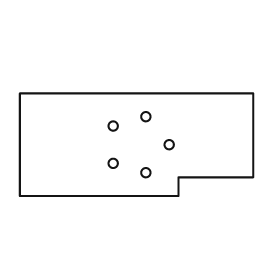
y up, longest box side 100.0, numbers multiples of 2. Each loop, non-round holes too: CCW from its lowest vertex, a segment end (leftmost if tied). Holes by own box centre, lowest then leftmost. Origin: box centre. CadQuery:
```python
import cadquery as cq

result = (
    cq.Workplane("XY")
    .moveTo(-50.0, -22.0)
    .lineTo(18.0, -22.0)
    .lineTo(18.0, -14.0)
    .lineTo(50.0, -14.0)
    .lineTo(50.0, 22.0)
    .lineTo(-50.0, 22.0)
    .close()
    .moveTo(4.0, -12.0)
    .circle(2.0)
    .moveTo(-10.0, -8.0)
    .circle(2.0)
    .moveTo(14.0, 0.0)
    .circle(2.0)
    .moveTo(-10.0, 8.0)
    .circle(2.0)
    .moveTo(4.0, 12.0)
    .circle(2.0)
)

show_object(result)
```